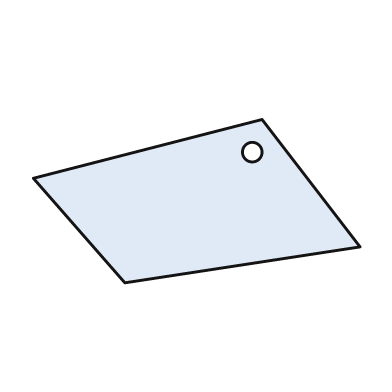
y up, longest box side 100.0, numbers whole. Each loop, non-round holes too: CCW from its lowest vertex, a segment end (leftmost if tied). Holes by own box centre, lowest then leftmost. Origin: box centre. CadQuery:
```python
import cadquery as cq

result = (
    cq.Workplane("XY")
    .moveTo(-22.0, -25.0)
    .lineTo(50.0, -14.0)
    .lineTo(20.0, 25.0)
    .lineTo(-50.0, 7.0)
    .close()
    .moveTo(17.0, 15.0)
    .circle(3.0)
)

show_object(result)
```